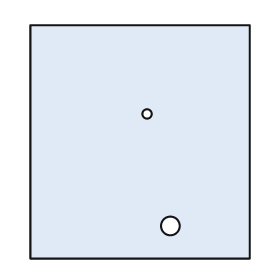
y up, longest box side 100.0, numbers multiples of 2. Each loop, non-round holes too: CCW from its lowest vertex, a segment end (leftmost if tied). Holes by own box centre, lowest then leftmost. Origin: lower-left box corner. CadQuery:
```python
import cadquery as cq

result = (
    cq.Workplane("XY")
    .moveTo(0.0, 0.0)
    .lineTo(94.0, 0.0)
    .lineTo(94.0, 100.0)
    .lineTo(0.0, 100.0)
    .close()
    .moveTo(60.0, 14.0)
    .circle(4.0)
    .moveTo(50.0, 62.0)
    .circle(2.0)
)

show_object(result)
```